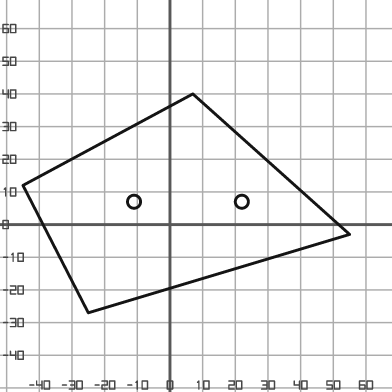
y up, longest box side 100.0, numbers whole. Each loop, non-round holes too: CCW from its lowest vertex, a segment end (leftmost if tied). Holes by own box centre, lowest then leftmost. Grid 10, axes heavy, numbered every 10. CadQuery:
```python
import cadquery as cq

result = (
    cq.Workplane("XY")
    .moveTo(-25.0, -27.0)
    .lineTo(55.0, -3.0)
    .lineTo(7.0, 40.0)
    .lineTo(-45.0, 12.0)
    .close()
    .moveTo(-11.0, 7.0)
    .circle(2.0)
    .moveTo(22.0, 7.0)
    .circle(2.0)
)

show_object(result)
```